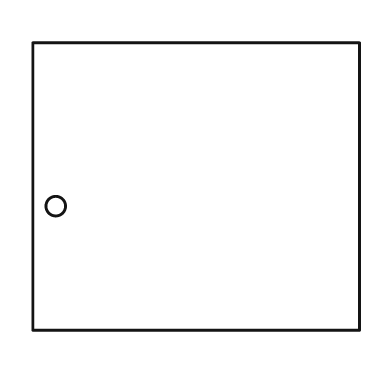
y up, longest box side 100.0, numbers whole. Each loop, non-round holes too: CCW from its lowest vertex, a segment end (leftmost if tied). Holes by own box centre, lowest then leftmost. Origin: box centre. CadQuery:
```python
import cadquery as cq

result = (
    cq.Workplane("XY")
    .moveTo(-50.0, -44.0)
    .lineTo(50.0, -44.0)
    .lineTo(50.0, 44.0)
    .lineTo(-50.0, 44.0)
    .close()
    .moveTo(-43.0, -6.0)
    .circle(3.0)
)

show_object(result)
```